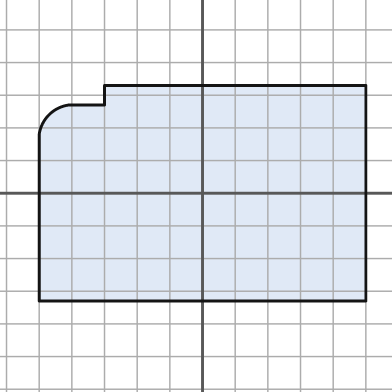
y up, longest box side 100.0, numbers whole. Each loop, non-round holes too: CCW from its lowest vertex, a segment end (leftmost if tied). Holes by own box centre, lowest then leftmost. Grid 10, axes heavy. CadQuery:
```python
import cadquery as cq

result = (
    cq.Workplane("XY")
    .moveTo(-50.0, -33.0)
    .lineTo(50.0, -33.0)
    .lineTo(50.0, 33.0)
    .lineTo(-30.0, 33.0)
    .lineTo(-30.0, 27.0)
    .lineTo(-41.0, 27.0)
    .threePointArc((-47.0, 24.0), (-50.0, 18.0))
    .close()
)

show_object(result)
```